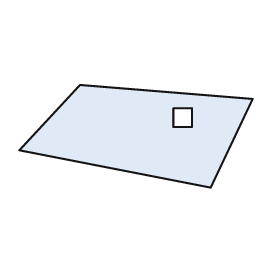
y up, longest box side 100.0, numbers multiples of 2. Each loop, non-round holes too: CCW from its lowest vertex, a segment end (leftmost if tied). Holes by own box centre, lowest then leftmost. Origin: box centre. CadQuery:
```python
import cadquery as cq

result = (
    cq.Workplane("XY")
    .moveTo(32.0, -22.0)
    .lineTo(50.0, 16.0)
    .lineTo(-24.0, 22.0)
    .lineTo(-50.0, -6.0)
    .close()
    .moveTo(16.0, 4.0)
    .lineTo(24.0, 4.0)
    .lineTo(24.0, 12.0)
    .lineTo(16.0, 12.0)
    .close()
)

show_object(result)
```